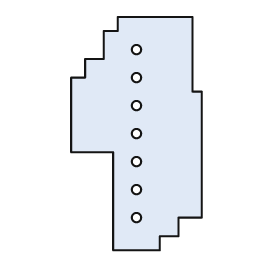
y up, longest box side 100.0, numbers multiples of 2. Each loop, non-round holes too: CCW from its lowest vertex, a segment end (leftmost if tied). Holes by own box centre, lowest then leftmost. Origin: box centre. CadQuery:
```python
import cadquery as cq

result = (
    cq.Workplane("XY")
    .moveTo(-10.0, -50.0)
    .lineTo(10.0, -50.0)
    .lineTo(10.0, -44.0)
    .lineTo(18.0, -44.0)
    .lineTo(18.0, -36.0)
    .lineTo(28.0, -36.0)
    .lineTo(28.0, 18.0)
    .lineTo(24.0, 18.0)
    .lineTo(24.0, 50.0)
    .lineTo(-8.0, 50.0)
    .lineTo(-8.0, 44.0)
    .lineTo(-14.0, 44.0)
    .lineTo(-14.0, 32.0)
    .lineTo(-22.0, 32.0)
    .lineTo(-22.0, 24.0)
    .lineTo(-28.0, 24.0)
    .lineTo(-28.0, -8.0)
    .lineTo(-10.0, -8.0)
    .close()
    .moveTo(0.0, -36.0)
    .circle(2.0)
    .moveTo(0.0, -24.0)
    .circle(2.0)
    .moveTo(0.0, -12.0)
    .circle(2.0)
    .moveTo(0.0, 0.0)
    .circle(2.0)
    .moveTo(0.0, 12.0)
    .circle(2.0)
    .moveTo(0.0, 24.0)
    .circle(2.0)
    .moveTo(0.0, 36.0)
    .circle(2.0)
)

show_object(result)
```